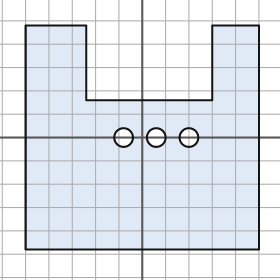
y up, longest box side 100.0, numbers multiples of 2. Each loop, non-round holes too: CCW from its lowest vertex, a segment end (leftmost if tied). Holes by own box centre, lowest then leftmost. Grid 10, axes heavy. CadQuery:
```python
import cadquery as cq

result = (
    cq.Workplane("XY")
    .moveTo(-50.0, -48.0)
    .lineTo(50.0, -48.0)
    .lineTo(50.0, 48.0)
    .lineTo(30.0, 48.0)
    .lineTo(30.0, 16.0)
    .lineTo(-24.0, 16.0)
    .lineTo(-24.0, 48.0)
    .lineTo(-50.0, 48.0)
    .close()
    .moveTo(-8.0, 0.0)
    .circle(4.0)
    .moveTo(6.0, 0.0)
    .circle(4.0)
    .moveTo(20.0, 0.0)
    .circle(4.0)
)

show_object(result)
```